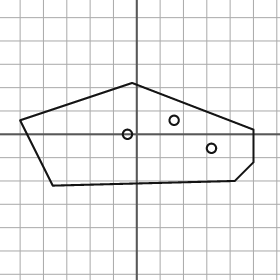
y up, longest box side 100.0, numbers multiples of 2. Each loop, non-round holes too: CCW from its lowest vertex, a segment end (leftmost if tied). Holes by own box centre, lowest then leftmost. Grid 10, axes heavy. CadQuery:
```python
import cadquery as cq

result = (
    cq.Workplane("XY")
    .moveTo(-36.0, -22.0)
    .lineTo(42.0, -20.0)
    .lineTo(50.0, -12.0)
    .lineTo(50.0, 2.0)
    .lineTo(-2.0, 22.0)
    .lineTo(-50.0, 6.0)
    .close()
    .moveTo(32.0, -6.0)
    .circle(2.0)
    .moveTo(-4.0, 0.0)
    .circle(2.0)
    .moveTo(16.0, 6.0)
    .circle(2.0)
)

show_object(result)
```